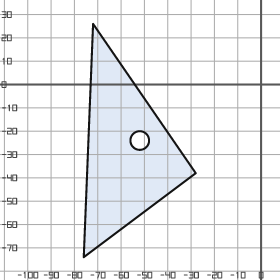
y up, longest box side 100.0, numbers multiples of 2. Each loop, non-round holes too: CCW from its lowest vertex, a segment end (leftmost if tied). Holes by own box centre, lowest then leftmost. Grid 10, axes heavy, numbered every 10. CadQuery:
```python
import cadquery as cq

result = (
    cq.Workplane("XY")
    .moveTo(-76.0, -74.0)
    .lineTo(-28.0, -38.0)
    .lineTo(-72.0, 26.0)
    .close()
    .moveTo(-52.0, -24.0)
    .circle(4.0)
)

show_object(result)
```